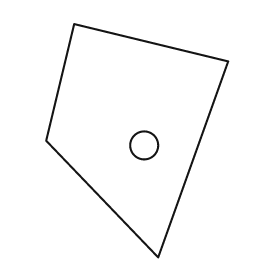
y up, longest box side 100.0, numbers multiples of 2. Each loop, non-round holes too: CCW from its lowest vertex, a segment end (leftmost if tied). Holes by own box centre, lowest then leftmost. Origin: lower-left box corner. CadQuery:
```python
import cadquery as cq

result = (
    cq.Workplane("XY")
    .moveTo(48.0, 0.0)
    .lineTo(78.0, 84.0)
    .lineTo(12.0, 100.0)
    .lineTo(0.0, 50.0)
    .close()
    .moveTo(42.0, 48.0)
    .circle(6.0)
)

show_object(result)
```